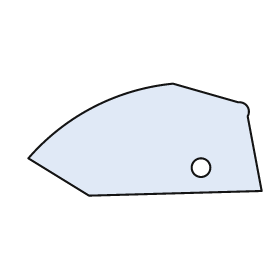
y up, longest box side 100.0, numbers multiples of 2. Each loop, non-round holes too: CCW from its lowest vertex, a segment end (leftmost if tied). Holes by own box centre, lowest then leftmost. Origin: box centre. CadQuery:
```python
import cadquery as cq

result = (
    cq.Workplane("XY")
    .moveTo(-24.0, -24.0)
    .lineTo(50.0, -22.0)
    .lineTo(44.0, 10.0)
    .threePointArc((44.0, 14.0), (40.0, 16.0))
    .lineTo(12.0, 24.0)
    .threePointArc((-22.0, 14.0), (-50.0, -8.0))
    .close()
    .moveTo(24.0, -12.0)
    .circle(4.0)
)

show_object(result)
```